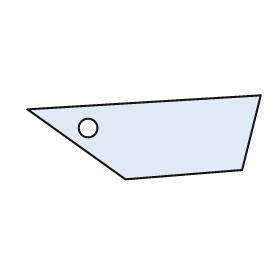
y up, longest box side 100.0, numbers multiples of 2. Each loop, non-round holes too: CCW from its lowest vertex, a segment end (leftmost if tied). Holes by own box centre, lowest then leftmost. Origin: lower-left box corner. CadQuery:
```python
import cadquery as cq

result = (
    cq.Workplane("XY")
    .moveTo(42.0, 0.0)
    .lineTo(92.0, 4.0)
    .lineTo(100.0, 36.0)
    .lineTo(0.0, 30.0)
    .close()
    .moveTo(26.0, 22.0)
    .circle(4.0)
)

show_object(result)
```